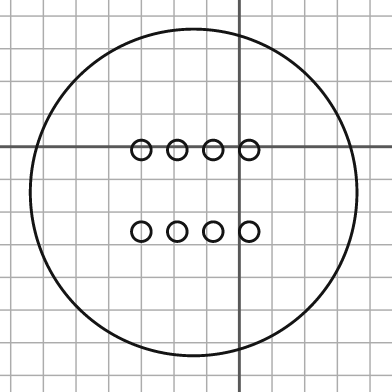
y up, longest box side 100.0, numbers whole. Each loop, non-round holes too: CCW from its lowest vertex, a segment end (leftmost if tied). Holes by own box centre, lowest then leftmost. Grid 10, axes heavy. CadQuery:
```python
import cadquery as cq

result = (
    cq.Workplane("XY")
    .moveTo(-14.0, -14.0)
    .circle(50.0)
    .moveTo(-30.0, -26.0)
    .circle(3.0)
    .moveTo(-19.0, -26.0)
    .circle(3.0)
    .moveTo(-8.0, -26.0)
    .circle(3.0)
    .moveTo(3.0, -26.0)
    .circle(3.0)
    .moveTo(-30.0, -1.0)
    .circle(3.0)
    .moveTo(-19.0, -1.0)
    .circle(3.0)
    .moveTo(-8.0, -1.0)
    .circle(3.0)
    .moveTo(3.0, -1.0)
    .circle(3.0)
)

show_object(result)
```